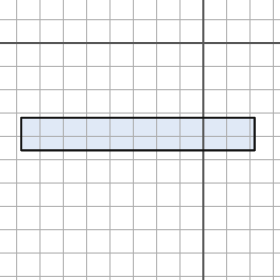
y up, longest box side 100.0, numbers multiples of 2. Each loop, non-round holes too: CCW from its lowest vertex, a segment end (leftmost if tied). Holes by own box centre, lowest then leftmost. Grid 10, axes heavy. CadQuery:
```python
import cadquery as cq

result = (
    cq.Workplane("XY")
    .moveTo(-78.0, -46.0)
    .lineTo(22.0, -46.0)
    .lineTo(22.0, -32.0)
    .lineTo(-78.0, -32.0)
    .close()
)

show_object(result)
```